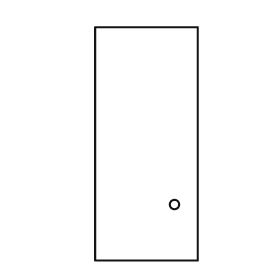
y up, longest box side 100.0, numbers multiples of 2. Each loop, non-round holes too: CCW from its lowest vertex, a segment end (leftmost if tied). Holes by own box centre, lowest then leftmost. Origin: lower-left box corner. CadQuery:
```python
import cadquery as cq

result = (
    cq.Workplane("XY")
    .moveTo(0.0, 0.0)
    .lineTo(44.0, 0.0)
    .lineTo(44.0, 100.0)
    .lineTo(0.0, 100.0)
    .close()
    .moveTo(34.0, 24.0)
    .circle(2.0)
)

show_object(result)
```